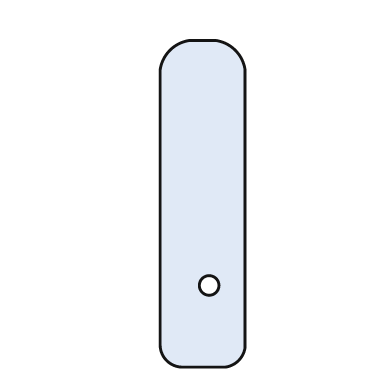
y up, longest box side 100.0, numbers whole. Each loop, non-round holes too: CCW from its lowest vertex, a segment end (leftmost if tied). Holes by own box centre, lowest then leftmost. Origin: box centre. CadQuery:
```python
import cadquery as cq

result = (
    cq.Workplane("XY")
    .moveTo(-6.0, -50.0)
    .lineTo(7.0, -50.0)
    .threePointArc((11.0, -48.0), (13.0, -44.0))
    .lineTo(13.0, 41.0)
    .threePointArc((10.0, 47.0), (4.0, 50.0))
    .lineTo(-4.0, 50.0)
    .threePointArc((-10.0, 47.0), (-13.0, 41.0))
    .lineTo(-13.0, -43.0)
    .threePointArc((-11.0, -48.0), (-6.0, -50.0))
    .close()
    .moveTo(2.0, -25.0)
    .circle(3.0)
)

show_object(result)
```